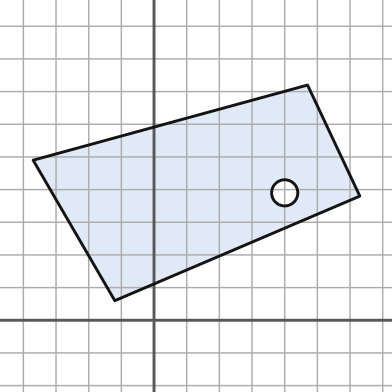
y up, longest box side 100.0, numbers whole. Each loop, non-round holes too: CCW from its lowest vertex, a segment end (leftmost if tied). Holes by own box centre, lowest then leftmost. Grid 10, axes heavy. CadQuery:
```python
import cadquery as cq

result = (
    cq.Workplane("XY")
    .moveTo(-12.0, 6.0)
    .lineTo(63.0, 38.0)
    .lineTo(47.0, 72.0)
    .lineTo(-37.0, 49.0)
    .close()
    .moveTo(40.0, 39.0)
    .circle(4.0)
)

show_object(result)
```